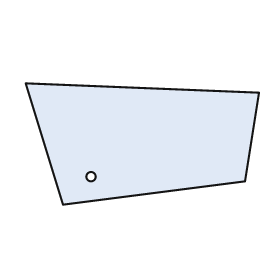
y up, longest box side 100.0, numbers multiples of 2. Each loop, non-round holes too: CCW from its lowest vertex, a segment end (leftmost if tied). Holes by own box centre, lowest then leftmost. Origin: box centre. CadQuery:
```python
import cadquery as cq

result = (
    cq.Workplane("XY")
    .moveTo(-34.0, -26.0)
    .lineTo(44.0, -16.0)
    .lineTo(50.0, 22.0)
    .lineTo(-50.0, 26.0)
    .close()
    .moveTo(-22.0, -14.0)
    .circle(2.0)
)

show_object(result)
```